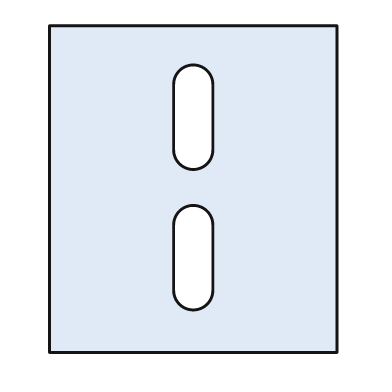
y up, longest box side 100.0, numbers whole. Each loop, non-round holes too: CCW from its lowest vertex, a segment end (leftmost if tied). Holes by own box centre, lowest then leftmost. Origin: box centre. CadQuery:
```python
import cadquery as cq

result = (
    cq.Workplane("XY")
    .moveTo(-44.0, -50.0)
    .lineTo(44.0, -50.0)
    .lineTo(44.0, 50.0)
    .lineTo(-44.0, 50.0)
    .close()
    .moveTo(-6.0, -31.0)
    .threePointArc((0.0, -37.0), (6.0, -31.0))
    .lineTo(6.0, -11.0)
    .threePointArc((0.0, -5.0), (-6.0, -11.0))
    .close()
    .moveTo(-6.0, 12.0)
    .threePointArc((0.0, 6.0), (6.0, 12.0))
    .lineTo(6.0, 32.0)
    .threePointArc((0.0, 38.0), (-6.0, 32.0))
    .close()
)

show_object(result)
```